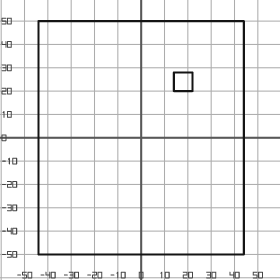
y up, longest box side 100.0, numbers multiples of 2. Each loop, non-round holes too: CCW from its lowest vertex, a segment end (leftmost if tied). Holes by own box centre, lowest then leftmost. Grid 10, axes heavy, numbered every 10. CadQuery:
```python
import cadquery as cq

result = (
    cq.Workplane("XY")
    .moveTo(-44.0, -50.0)
    .lineTo(44.0, -50.0)
    .lineTo(44.0, 50.0)
    .lineTo(-44.0, 50.0)
    .close()
    .moveTo(14.0, 20.0)
    .lineTo(22.0, 20.0)
    .lineTo(22.0, 28.0)
    .lineTo(14.0, 28.0)
    .close()
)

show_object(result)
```